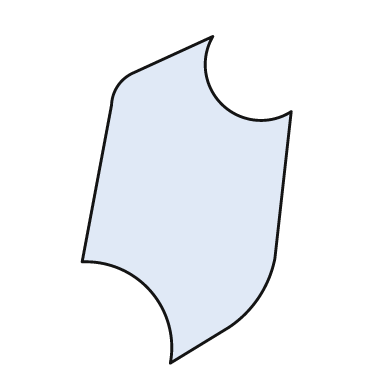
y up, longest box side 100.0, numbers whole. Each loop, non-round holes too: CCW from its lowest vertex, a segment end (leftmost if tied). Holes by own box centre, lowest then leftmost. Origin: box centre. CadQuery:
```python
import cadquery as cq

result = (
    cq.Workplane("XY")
    .moveTo(-5.0, -50.0)
    .lineTo(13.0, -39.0)
    .threePointArc((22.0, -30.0), (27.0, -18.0))
    .lineTo(32.0, 27.0)
    .threePointArc((11.0, 29.0), (8.0, 50.0))
    .lineTo(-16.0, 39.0)
    .threePointArc((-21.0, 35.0), (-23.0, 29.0))
    .lineTo(-32.0, -19.0)
    .threePointArc((-11.0, -28.0), (-5.0, -50.0))
    .close()
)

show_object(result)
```